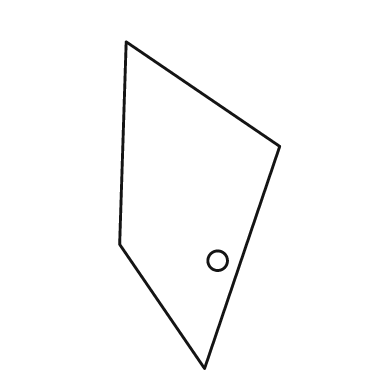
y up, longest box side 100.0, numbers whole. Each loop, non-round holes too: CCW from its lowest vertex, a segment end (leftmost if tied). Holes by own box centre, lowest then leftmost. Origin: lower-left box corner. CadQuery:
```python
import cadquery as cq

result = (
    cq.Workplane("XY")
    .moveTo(26.0, 0.0)
    .lineTo(49.0, 68.0)
    .lineTo(2.0, 100.0)
    .lineTo(0.0, 38.0)
    .close()
    .moveTo(30.0, 33.0)
    .circle(3.0)
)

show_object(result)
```